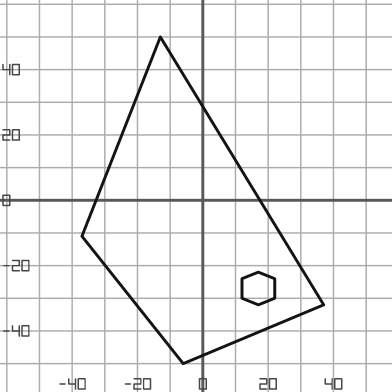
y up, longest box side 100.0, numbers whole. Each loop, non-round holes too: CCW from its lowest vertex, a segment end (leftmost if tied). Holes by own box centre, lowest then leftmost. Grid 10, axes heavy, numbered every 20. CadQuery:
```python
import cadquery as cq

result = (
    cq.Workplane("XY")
    .moveTo(-6.0, -50.0)
    .lineTo(37.0, -32.0)
    .lineTo(-13.0, 50.0)
    .lineTo(-37.0, -11.0)
    .close()
    .moveTo(17.0, -32.0)
    .lineTo(22.0, -30.0)
    .lineTo(22.0, -24.0)
    .lineTo(17.0, -22.0)
    .lineTo(12.0, -24.0)
    .lineTo(12.0, -30.0)
    .close()
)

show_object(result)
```